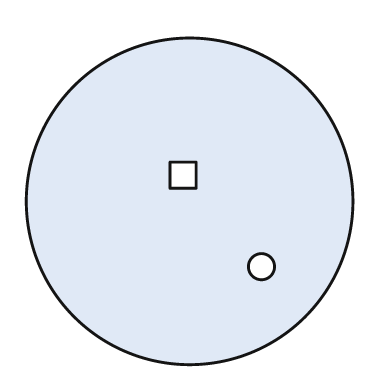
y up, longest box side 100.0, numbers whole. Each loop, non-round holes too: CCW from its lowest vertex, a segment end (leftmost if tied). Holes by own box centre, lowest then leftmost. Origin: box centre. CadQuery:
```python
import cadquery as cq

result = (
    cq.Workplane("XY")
    .moveTo(0.0, 0.0)
    .circle(50.0)
    .moveTo(22.0, -20.0)
    .circle(4.0)
    .moveTo(-6.0, 4.0)
    .lineTo(2.0, 4.0)
    .lineTo(2.0, 12.0)
    .lineTo(-6.0, 12.0)
    .close()
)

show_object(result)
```